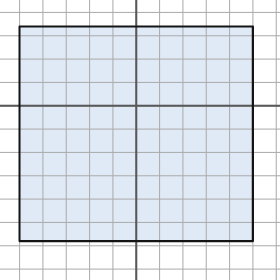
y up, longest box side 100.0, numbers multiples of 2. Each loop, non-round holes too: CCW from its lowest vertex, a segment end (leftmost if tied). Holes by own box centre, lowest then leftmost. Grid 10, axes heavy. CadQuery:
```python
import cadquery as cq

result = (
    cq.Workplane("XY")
    .moveTo(-50.0, -58.0)
    .lineTo(50.0, -58.0)
    .lineTo(50.0, 34.0)
    .lineTo(-50.0, 34.0)
    .close()
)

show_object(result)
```